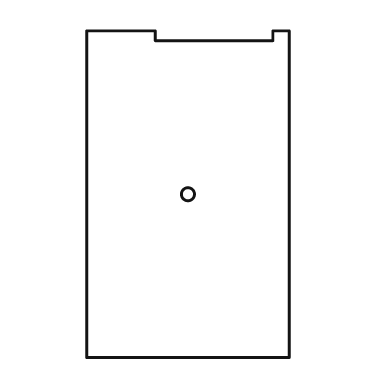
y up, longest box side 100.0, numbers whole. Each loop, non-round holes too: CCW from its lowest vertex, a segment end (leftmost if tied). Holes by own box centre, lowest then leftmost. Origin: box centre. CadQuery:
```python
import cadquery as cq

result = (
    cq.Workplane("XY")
    .moveTo(-31.0, -50.0)
    .lineTo(31.0, -50.0)
    .lineTo(31.0, 50.0)
    .lineTo(26.0, 50.0)
    .lineTo(26.0, 47.0)
    .lineTo(-10.0, 47.0)
    .lineTo(-10.0, 50.0)
    .lineTo(-31.0, 50.0)
    .close()
    .moveTo(0.0, 0.0)
    .circle(2.0)
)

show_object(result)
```